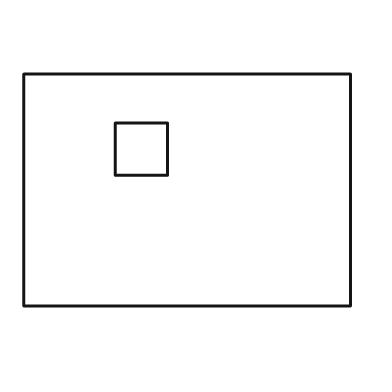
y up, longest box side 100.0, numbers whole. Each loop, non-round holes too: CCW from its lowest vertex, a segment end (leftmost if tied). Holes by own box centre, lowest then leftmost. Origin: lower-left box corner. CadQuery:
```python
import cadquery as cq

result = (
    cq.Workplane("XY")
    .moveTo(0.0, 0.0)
    .lineTo(100.0, 0.0)
    .lineTo(100.0, 71.0)
    .lineTo(0.0, 71.0)
    .close()
    .moveTo(28.0, 40.0)
    .lineTo(44.0, 40.0)
    .lineTo(44.0, 56.0)
    .lineTo(28.0, 56.0)
    .close()
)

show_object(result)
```